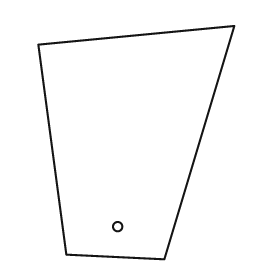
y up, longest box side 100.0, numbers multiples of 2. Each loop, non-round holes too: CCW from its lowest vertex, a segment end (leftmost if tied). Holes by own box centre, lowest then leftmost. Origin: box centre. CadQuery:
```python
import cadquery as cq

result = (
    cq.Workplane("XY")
    .moveTo(12.0, -50.0)
    .lineTo(42.0, 50.0)
    .lineTo(-42.0, 42.0)
    .lineTo(-30.0, -48.0)
    .close()
    .moveTo(-8.0, -36.0)
    .circle(2.0)
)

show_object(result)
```